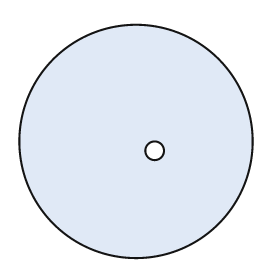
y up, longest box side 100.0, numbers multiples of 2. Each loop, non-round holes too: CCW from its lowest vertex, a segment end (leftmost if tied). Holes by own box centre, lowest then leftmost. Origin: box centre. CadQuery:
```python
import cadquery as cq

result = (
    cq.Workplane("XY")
    .moveTo(0.0, 0.0)
    .circle(50.0)
    .moveTo(8.0, -4.0)
    .circle(4.0)
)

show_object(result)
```